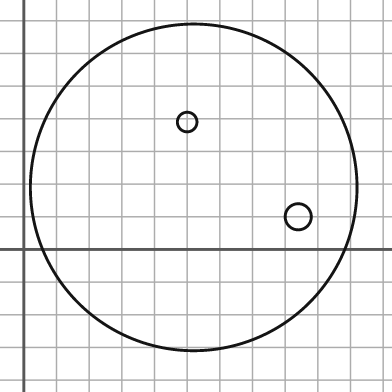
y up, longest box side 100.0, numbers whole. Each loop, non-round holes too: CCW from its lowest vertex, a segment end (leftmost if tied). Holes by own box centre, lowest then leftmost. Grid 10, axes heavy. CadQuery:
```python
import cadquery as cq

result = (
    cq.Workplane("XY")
    .moveTo(52.0, 19.0)
    .circle(50.0)
    .moveTo(84.0, 10.0)
    .circle(4.0)
    .moveTo(50.0, 39.0)
    .circle(3.0)
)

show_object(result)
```